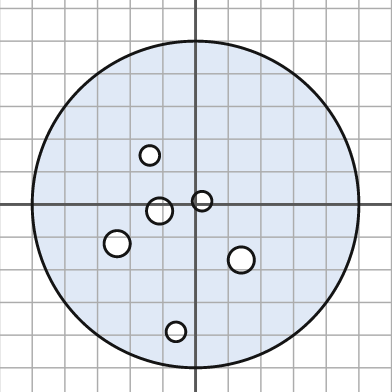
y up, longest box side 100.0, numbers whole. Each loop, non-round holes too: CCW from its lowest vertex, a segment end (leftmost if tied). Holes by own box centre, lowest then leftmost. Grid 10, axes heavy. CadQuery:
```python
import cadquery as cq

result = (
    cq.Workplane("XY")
    .moveTo(0.0, 0.0)
    .circle(50.0)
    .moveTo(-6.0, -39.0)
    .circle(3.0)
    .moveTo(14.0, -17.0)
    .circle(4.0)
    .moveTo(-24.0, -12.0)
    .circle(4.0)
    .moveTo(-11.0, -2.0)
    .circle(4.0)
    .moveTo(2.0, 1.0)
    .circle(3.0)
    .moveTo(-14.0, 15.0)
    .circle(3.0)
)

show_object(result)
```